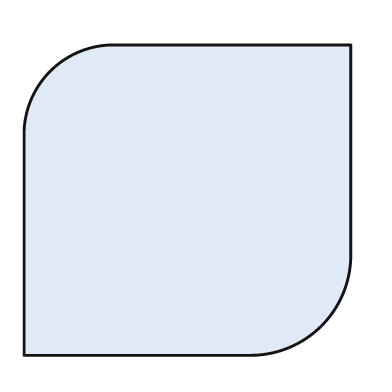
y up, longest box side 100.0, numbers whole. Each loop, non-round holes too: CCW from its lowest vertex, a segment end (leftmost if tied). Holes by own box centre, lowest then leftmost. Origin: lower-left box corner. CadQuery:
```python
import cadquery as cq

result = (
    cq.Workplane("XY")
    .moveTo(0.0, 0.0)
    .lineTo(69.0, 0.0)
    .threePointArc((91.0, 9.0), (100.0, 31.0))
    .lineTo(100.0, 95.0)
    .lineTo(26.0, 95.0)
    .threePointArc((8.0, 87.0), (0.0, 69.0))
    .close()
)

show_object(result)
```